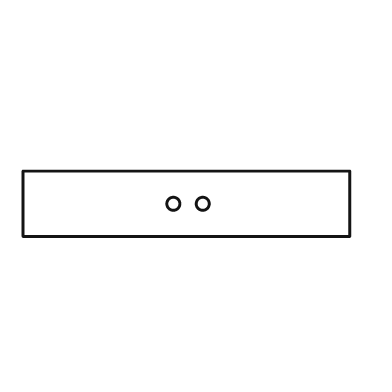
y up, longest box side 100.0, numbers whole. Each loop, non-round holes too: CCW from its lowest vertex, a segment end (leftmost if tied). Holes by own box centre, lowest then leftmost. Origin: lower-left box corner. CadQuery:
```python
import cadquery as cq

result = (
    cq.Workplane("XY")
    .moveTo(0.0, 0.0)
    .lineTo(100.0, 0.0)
    .lineTo(100.0, 20.0)
    .lineTo(0.0, 20.0)
    .close()
    .moveTo(46.0, 10.0)
    .circle(2.0)
    .moveTo(55.0, 10.0)
    .circle(2.0)
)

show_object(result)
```